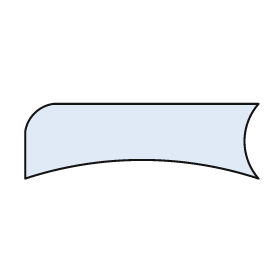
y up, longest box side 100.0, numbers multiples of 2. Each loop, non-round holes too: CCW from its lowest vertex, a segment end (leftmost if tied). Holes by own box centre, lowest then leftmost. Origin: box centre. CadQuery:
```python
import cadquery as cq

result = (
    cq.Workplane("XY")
    .moveTo(-50.0, -16.0)
    .threePointArc((0.0, -8.0), (50.0, -16.0))
    .threePointArc((44.0, 0.0), (50.0, 16.0))
    .lineTo(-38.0, 16.0)
    .threePointArc((-46.0, 12.0), (-50.0, 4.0))
    .close()
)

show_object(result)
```